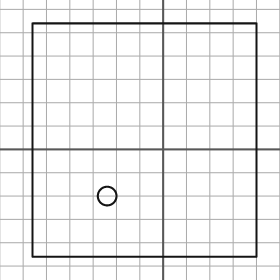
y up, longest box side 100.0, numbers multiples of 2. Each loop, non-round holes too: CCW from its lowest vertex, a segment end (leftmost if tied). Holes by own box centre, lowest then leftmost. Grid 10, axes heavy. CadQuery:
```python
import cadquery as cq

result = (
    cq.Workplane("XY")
    .moveTo(-56.0, -46.0)
    .lineTo(40.0, -46.0)
    .lineTo(40.0, 54.0)
    .lineTo(-56.0, 54.0)
    .close()
    .moveTo(-24.0, -20.0)
    .circle(4.0)
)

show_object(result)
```